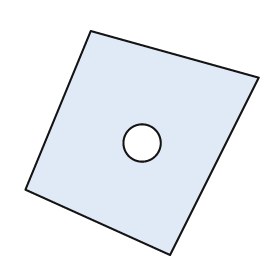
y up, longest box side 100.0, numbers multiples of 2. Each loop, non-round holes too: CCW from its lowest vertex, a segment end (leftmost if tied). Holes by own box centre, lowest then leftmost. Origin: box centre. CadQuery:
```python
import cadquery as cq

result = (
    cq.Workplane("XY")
    .moveTo(12.0, -48.0)
    .lineTo(50.0, 28.0)
    .lineTo(-22.0, 48.0)
    .lineTo(-50.0, -20.0)
    .close()
    .moveTo(0.0, 0.0)
    .circle(8.0)
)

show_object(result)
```